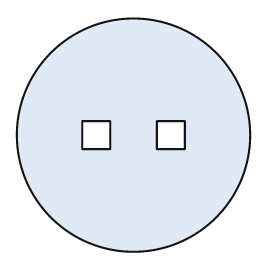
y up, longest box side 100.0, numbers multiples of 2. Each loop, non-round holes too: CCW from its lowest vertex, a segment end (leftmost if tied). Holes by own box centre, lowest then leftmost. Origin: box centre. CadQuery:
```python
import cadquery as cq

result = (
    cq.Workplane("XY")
    .moveTo(0.0, 0.0)
    .circle(50.0)
    .moveTo(-22.0, -6.0)
    .lineTo(-10.0, -6.0)
    .lineTo(-10.0, 6.0)
    .lineTo(-22.0, 6.0)
    .close()
    .moveTo(10.0, -6.0)
    .lineTo(22.0, -6.0)
    .lineTo(22.0, 6.0)
    .lineTo(10.0, 6.0)
    .close()
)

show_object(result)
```